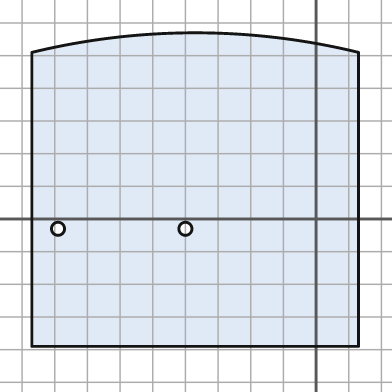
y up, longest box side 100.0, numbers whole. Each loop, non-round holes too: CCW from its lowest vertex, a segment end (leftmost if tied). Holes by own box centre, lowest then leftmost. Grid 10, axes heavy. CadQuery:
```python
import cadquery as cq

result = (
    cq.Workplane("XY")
    .moveTo(-87.0, -39.0)
    .lineTo(13.0, -39.0)
    .lineTo(13.0, 51.0)
    .threePointArc((-37.0, 57.0), (-87.0, 51.0))
    .close()
    .moveTo(-79.0, -3.0)
    .circle(2.0)
    .moveTo(-40.0, -3.0)
    .circle(2.0)
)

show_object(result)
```